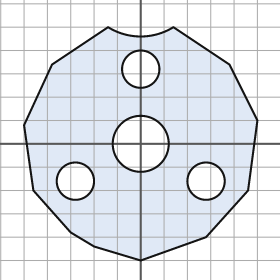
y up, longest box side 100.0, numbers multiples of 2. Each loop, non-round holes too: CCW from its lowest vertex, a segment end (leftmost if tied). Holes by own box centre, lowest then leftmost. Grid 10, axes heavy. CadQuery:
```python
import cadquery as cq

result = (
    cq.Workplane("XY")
    .moveTo(0.0, -50.0)
    .lineTo(28.0, -40.0)
    .lineTo(46.0, -20.0)
    .lineTo(50.0, 10.0)
    .lineTo(38.0, 34.0)
    .lineTo(14.0, 50.0)
    .threePointArc((0.0, 46.0), (-14.0, 50.0))
    .lineTo(-38.0, 34.0)
    .lineTo(-50.0, 8.0)
    .lineTo(-46.0, -20.0)
    .lineTo(-30.0, -38.0)
    .lineTo(-20.0, -44.0)
    .close()
    .moveTo(-28.0, -16.0)
    .circle(8.0)
    .moveTo(28.0, -16.0)
    .circle(8.0)
    .moveTo(0.0, 0.0)
    .circle(12.0)
    .moveTo(0.0, 32.0)
    .circle(8.0)
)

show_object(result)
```